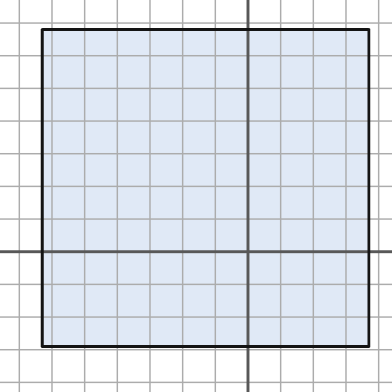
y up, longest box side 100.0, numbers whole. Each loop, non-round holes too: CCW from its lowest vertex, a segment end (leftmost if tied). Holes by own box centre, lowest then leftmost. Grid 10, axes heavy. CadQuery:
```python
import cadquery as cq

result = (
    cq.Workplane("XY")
    .moveTo(-63.0, -29.0)
    .lineTo(37.0, -29.0)
    .lineTo(37.0, 68.0)
    .lineTo(-63.0, 68.0)
    .close()
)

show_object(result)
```